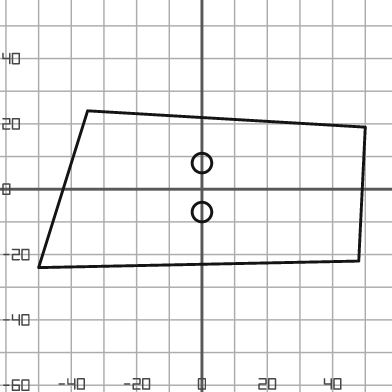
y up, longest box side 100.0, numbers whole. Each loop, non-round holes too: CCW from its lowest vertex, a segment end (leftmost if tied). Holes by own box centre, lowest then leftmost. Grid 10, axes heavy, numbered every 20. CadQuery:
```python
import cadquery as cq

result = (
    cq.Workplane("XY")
    .moveTo(-50.0, -24.0)
    .lineTo(48.0, -22.0)
    .lineTo(50.0, 19.0)
    .lineTo(-35.0, 24.0)
    .close()
    .moveTo(0.0, -7.0)
    .circle(3.0)
    .moveTo(0.0, 8.0)
    .circle(3.0)
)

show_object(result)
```